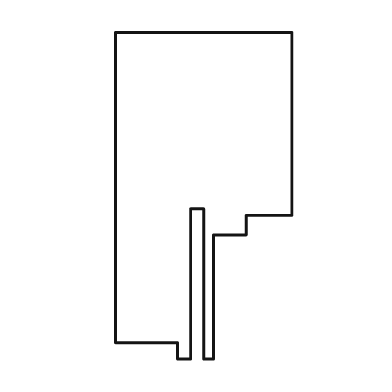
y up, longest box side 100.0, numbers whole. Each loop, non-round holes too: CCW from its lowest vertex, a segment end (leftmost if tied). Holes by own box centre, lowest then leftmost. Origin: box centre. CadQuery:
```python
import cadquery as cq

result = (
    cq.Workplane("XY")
    .moveTo(-8.0, -50.0)
    .lineTo(-4.0, -50.0)
    .lineTo(-4.0, -4.0)
    .lineTo(0.0, -4.0)
    .lineTo(0.0, -50.0)
    .lineTo(3.0, -50.0)
    .lineTo(3.0, -12.0)
    .lineTo(13.0, -12.0)
    .lineTo(13.0, -6.0)
    .lineTo(27.0, -6.0)
    .lineTo(27.0, 50.0)
    .lineTo(-27.0, 50.0)
    .lineTo(-27.0, -45.0)
    .lineTo(-8.0, -45.0)
    .close()
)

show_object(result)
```